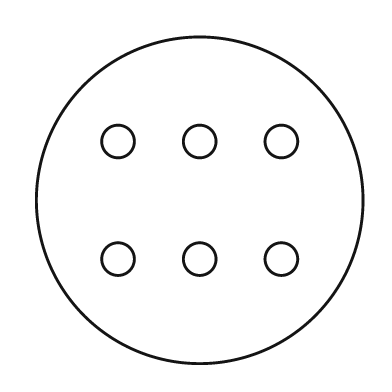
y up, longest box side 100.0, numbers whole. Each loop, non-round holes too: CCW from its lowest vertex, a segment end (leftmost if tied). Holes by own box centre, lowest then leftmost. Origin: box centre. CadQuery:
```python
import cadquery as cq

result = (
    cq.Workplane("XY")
    .moveTo(0.0, 0.0)
    .circle(50.0)
    .moveTo(-25.0, -18.0)
    .circle(5.0)
    .moveTo(0.0, -18.0)
    .circle(5.0)
    .moveTo(25.0, -18.0)
    .circle(5.0)
    .moveTo(-25.0, 18.0)
    .circle(5.0)
    .moveTo(0.0, 18.0)
    .circle(5.0)
    .moveTo(25.0, 18.0)
    .circle(5.0)
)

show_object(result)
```